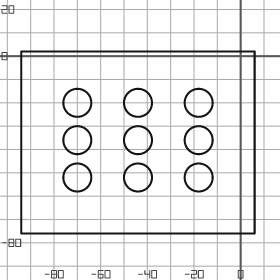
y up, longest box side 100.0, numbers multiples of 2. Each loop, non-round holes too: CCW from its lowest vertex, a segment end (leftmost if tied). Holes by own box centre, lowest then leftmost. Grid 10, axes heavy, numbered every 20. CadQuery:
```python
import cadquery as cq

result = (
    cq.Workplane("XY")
    .moveTo(-94.0, -76.0)
    .lineTo(6.0, -76.0)
    .lineTo(6.0, 2.0)
    .lineTo(-94.0, 2.0)
    .close()
    .moveTo(-70.0, -52.0)
    .circle(6.0)
    .moveTo(-44.0, -52.0)
    .circle(6.0)
    .moveTo(-18.0, -52.0)
    .circle(6.0)
    .moveTo(-70.0, -36.0)
    .circle(6.0)
    .moveTo(-44.0, -36.0)
    .circle(6.0)
    .moveTo(-18.0, -36.0)
    .circle(6.0)
    .moveTo(-70.0, -20.0)
    .circle(6.0)
    .moveTo(-44.0, -20.0)
    .circle(6.0)
    .moveTo(-18.0, -20.0)
    .circle(6.0)
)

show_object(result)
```